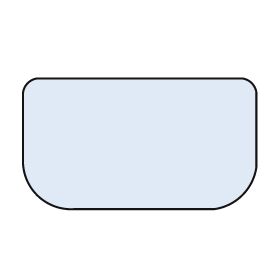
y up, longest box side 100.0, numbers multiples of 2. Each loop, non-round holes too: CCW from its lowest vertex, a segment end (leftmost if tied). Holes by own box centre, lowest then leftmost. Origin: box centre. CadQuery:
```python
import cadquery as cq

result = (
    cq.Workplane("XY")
    .moveTo(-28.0, -28.0)
    .lineTo(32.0, -28.0)
    .threePointArc((44.0, -22.0), (50.0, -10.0))
    .lineTo(50.0, 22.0)
    .threePointArc((48.0, 26.0), (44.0, 28.0))
    .lineTo(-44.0, 28.0)
    .threePointArc((-48.0, 26.0), (-50.0, 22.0))
    .lineTo(-50.0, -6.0)
    .threePointArc((-44.0, -22.0), (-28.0, -28.0))
    .close()
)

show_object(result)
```